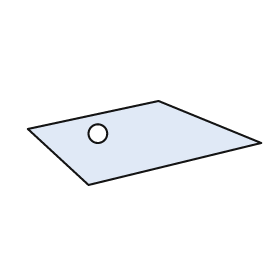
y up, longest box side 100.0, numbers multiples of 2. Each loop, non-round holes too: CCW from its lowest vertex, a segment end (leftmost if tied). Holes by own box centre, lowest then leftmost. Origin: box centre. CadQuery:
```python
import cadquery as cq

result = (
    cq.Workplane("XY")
    .moveTo(-24.0, -18.0)
    .lineTo(50.0, 0.0)
    .lineTo(6.0, 18.0)
    .lineTo(-50.0, 6.0)
    .close()
    .moveTo(-20.0, 4.0)
    .circle(4.0)
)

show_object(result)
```